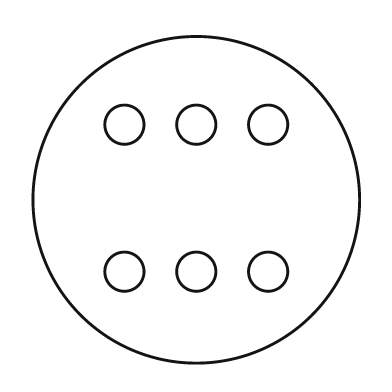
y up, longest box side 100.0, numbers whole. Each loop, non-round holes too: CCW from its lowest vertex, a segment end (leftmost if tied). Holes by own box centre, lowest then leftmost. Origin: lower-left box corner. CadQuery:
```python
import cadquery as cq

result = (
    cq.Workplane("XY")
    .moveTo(50.0, 50.0)
    .circle(50.0)
    .moveTo(28.0, 28.0)
    .circle(6.0)
    .moveTo(50.0, 28.0)
    .circle(6.0)
    .moveTo(72.0, 28.0)
    .circle(6.0)
    .moveTo(28.0, 73.0)
    .circle(6.0)
    .moveTo(50.0, 73.0)
    .circle(6.0)
    .moveTo(72.0, 73.0)
    .circle(6.0)
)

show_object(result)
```